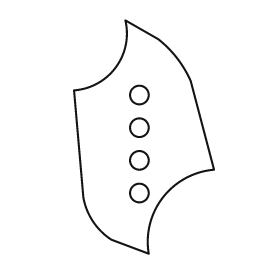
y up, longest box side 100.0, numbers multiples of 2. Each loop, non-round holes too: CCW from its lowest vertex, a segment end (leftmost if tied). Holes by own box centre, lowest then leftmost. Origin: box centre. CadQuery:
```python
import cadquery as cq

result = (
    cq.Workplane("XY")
    .moveTo(2.0, -50.0)
    .threePointArc((8.0, -26.0), (30.0, -14.0))
    .lineTo(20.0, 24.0)
    .threePointArc((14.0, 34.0), (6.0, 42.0))
    .lineTo(-8.0, 50.0)
    .threePointArc((-12.0, 30.0), (-30.0, 20.0))
    .lineTo(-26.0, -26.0)
    .threePointArc((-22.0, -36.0), (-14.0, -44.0))
    .close()
    .moveTo(-2.0, -24.0)
    .circle(4.0)
    .moveTo(-2.0, -10.0)
    .circle(4.0)
    .moveTo(-2.0, 4.0)
    .circle(4.0)
    .moveTo(-2.0, 18.0)
    .circle(4.0)
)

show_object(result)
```